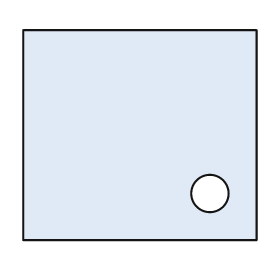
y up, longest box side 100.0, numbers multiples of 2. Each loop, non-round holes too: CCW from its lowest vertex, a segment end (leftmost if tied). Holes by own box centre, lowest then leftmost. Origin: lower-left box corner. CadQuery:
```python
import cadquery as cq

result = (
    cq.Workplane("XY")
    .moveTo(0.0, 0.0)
    .lineTo(100.0, 0.0)
    .lineTo(100.0, 90.0)
    .lineTo(0.0, 90.0)
    .close()
    .moveTo(80.0, 20.0)
    .circle(8.0)
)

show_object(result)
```